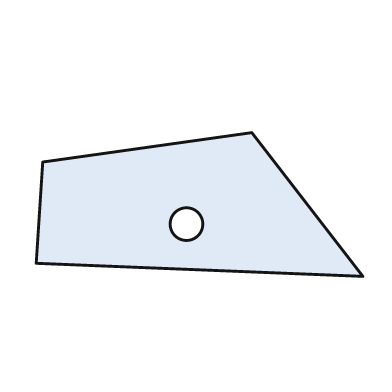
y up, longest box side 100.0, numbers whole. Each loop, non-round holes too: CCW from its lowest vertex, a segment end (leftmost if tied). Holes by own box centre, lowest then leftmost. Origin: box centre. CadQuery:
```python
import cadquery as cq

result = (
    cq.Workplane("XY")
    .moveTo(50.0, -22.0)
    .lineTo(16.0, 22.0)
    .lineTo(-48.0, 13.0)
    .lineTo(-50.0, -18.0)
    .close()
    .moveTo(-4.0, -6.0)
    .circle(5.0)
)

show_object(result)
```